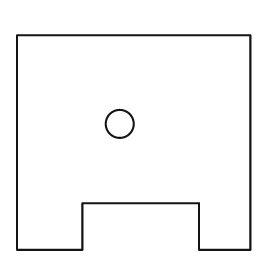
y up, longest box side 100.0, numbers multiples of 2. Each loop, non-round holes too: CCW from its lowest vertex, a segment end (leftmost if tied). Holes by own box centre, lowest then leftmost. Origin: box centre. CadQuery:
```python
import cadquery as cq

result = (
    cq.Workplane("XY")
    .moveTo(-50.0, -46.0)
    .lineTo(-22.0, -46.0)
    .lineTo(-22.0, -26.0)
    .lineTo(28.0, -26.0)
    .lineTo(28.0, -46.0)
    .lineTo(50.0, -46.0)
    .lineTo(50.0, 46.0)
    .lineTo(-50.0, 46.0)
    .close()
    .moveTo(-6.0, 8.0)
    .circle(6.0)
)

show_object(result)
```